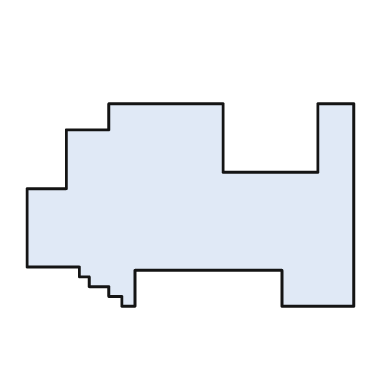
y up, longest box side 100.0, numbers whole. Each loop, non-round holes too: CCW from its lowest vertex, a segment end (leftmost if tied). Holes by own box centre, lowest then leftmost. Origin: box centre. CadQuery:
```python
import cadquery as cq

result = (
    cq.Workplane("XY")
    .moveTo(-21.0, -31.0)
    .lineTo(-17.0, -31.0)
    .lineTo(-17.0, -20.0)
    .lineTo(28.0, -20.0)
    .lineTo(28.0, -31.0)
    .lineTo(50.0, -31.0)
    .lineTo(50.0, 31.0)
    .lineTo(39.0, 31.0)
    .lineTo(39.0, 10.0)
    .lineTo(10.0, 10.0)
    .lineTo(10.0, 31.0)
    .lineTo(-25.0, 31.0)
    .lineTo(-25.0, 23.0)
    .lineTo(-38.0, 23.0)
    .lineTo(-38.0, 5.0)
    .lineTo(-50.0, 5.0)
    .lineTo(-50.0, -19.0)
    .lineTo(-34.0, -19.0)
    .lineTo(-34.0, -22.0)
    .lineTo(-31.0, -22.0)
    .lineTo(-31.0, -25.0)
    .lineTo(-25.0, -25.0)
    .lineTo(-25.0, -28.0)
    .lineTo(-21.0, -28.0)
    .close()
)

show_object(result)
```